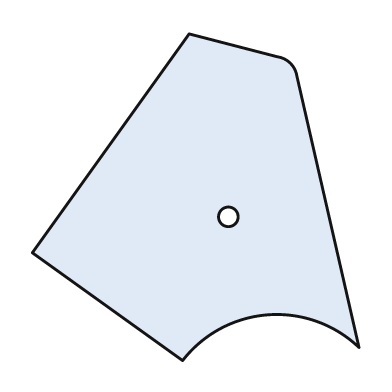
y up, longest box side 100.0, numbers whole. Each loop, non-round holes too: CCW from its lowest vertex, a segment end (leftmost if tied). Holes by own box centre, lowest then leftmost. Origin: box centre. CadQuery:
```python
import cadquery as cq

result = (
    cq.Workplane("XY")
    .moveTo(-4.0, -50.0)
    .threePointArc((22.0, -36.0), (50.0, -46.0))
    .lineTo(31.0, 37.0)
    .threePointArc((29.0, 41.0), (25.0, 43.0))
    .lineTo(-2.0, 50.0)
    .lineTo(-50.0, -17.0)
    .close()
    .moveTo(10.0, -6.0)
    .circle(3.0)
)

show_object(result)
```